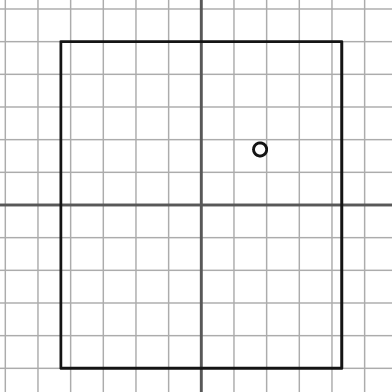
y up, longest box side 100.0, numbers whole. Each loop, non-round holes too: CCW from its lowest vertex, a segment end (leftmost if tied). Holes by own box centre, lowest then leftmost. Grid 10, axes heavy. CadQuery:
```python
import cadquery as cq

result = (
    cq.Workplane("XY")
    .moveTo(-43.0, -50.0)
    .lineTo(43.0, -50.0)
    .lineTo(43.0, 50.0)
    .lineTo(-43.0, 50.0)
    .close()
    .moveTo(18.0, 17.0)
    .circle(2.0)
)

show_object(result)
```